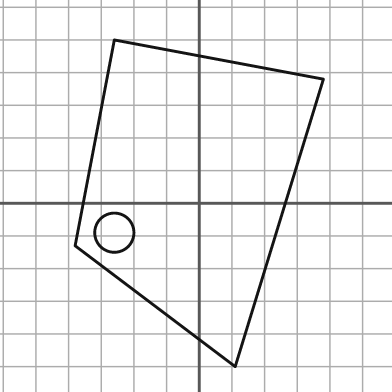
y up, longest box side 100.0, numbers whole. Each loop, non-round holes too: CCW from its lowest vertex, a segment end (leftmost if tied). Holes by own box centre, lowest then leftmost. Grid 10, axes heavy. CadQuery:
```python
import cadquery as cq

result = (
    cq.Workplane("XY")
    .moveTo(11.0, -50.0)
    .lineTo(38.0, 38.0)
    .lineTo(-26.0, 50.0)
    .lineTo(-38.0, -13.0)
    .close()
    .moveTo(-26.0, -9.0)
    .circle(6.0)
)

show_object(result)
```